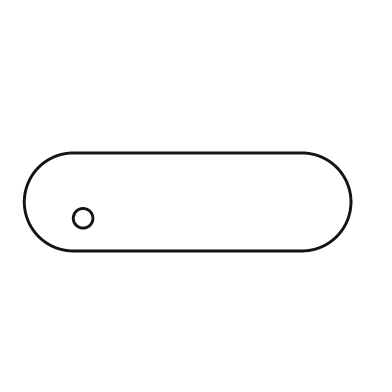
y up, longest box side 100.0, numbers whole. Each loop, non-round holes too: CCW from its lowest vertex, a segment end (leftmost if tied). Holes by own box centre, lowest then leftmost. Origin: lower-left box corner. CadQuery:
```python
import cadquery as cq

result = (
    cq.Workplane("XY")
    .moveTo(15.0, 0.0)
    .lineTo(85.0, 0.0)
    .threePointArc((100.0, 15.0), (85.0, 30.0))
    .lineTo(15.0, 30.0)
    .threePointArc((0.0, 15.0), (15.0, 0.0))
    .close()
    .moveTo(18.0, 10.0)
    .circle(3.0)
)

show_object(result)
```